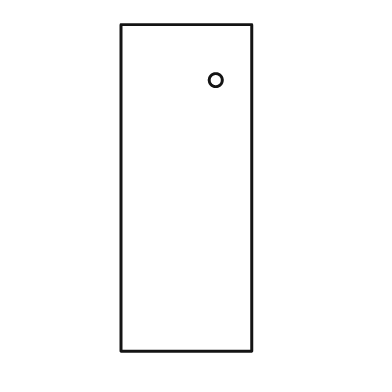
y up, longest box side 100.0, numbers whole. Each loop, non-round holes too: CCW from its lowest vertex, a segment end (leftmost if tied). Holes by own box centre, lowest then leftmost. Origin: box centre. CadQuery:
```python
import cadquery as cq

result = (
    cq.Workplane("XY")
    .moveTo(-20.0, -50.0)
    .lineTo(20.0, -50.0)
    .lineTo(20.0, 50.0)
    .lineTo(-20.0, 50.0)
    .close()
    .moveTo(9.0, 33.0)
    .circle(2.0)
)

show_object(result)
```